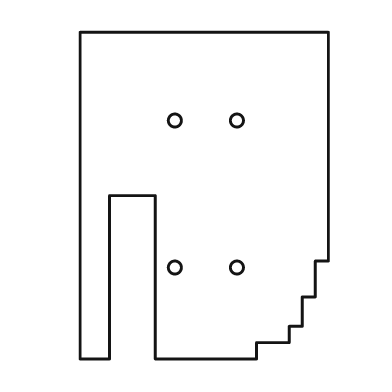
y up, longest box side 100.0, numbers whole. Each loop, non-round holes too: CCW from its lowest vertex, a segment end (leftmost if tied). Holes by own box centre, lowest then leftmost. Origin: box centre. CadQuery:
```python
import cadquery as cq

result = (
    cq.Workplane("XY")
    .moveTo(-38.0, -50.0)
    .lineTo(-29.0, -50.0)
    .lineTo(-29.0, 0.0)
    .lineTo(-15.0, 0.0)
    .lineTo(-15.0, -50.0)
    .lineTo(16.0, -50.0)
    .lineTo(16.0, -45.0)
    .lineTo(26.0, -45.0)
    .lineTo(26.0, -40.0)
    .lineTo(30.0, -40.0)
    .lineTo(30.0, -31.0)
    .lineTo(34.0, -31.0)
    .lineTo(34.0, -20.0)
    .lineTo(38.0, -20.0)
    .lineTo(38.0, 50.0)
    .lineTo(-38.0, 50.0)
    .close()
    .moveTo(-9.0, -22.0)
    .circle(2.0)
    .moveTo(10.0, -22.0)
    .circle(2.0)
    .moveTo(-9.0, 23.0)
    .circle(2.0)
    .moveTo(10.0, 23.0)
    .circle(2.0)
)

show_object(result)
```